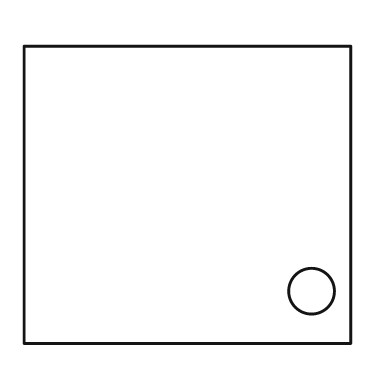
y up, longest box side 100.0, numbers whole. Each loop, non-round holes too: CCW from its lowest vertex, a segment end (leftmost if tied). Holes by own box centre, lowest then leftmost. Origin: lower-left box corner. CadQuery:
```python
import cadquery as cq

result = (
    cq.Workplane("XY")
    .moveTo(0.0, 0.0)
    .lineTo(100.0, 0.0)
    .lineTo(100.0, 91.0)
    .lineTo(0.0, 91.0)
    .close()
    .moveTo(88.0, 16.0)
    .circle(7.0)
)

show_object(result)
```